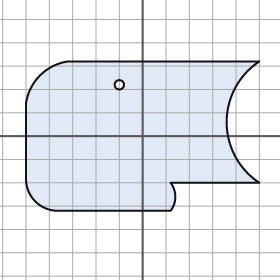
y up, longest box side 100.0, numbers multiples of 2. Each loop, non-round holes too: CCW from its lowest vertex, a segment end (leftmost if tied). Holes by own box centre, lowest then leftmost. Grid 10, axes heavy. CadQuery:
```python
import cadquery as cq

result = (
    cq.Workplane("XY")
    .moveTo(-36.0, -32.0)
    .lineTo(12.0, -32.0)
    .threePointArc((14.0, -26.0), (12.0, -20.0))
    .lineTo(50.0, -20.0)
    .threePointArc((36.0, 6.0), (50.0, 32.0))
    .lineTo(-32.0, 32.0)
    .threePointArc((-44.0, 26.0), (-50.0, 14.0))
    .lineTo(-50.0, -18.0)
    .threePointArc((-46.0, -28.0), (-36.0, -32.0))
    .close()
    .moveTo(-10.0, 22.0)
    .circle(2.0)
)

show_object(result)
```